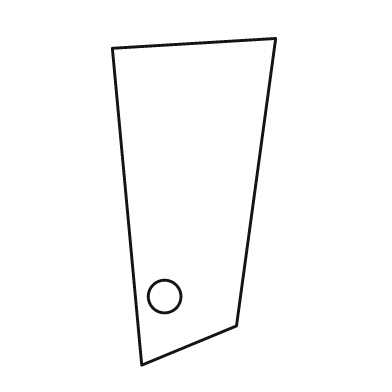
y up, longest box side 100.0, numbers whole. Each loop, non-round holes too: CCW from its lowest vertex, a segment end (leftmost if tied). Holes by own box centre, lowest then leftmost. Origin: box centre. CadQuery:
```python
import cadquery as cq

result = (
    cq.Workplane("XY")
    .moveTo(-16.0, -50.0)
    .lineTo(13.0, -38.0)
    .lineTo(25.0, 50.0)
    .lineTo(-25.0, 47.0)
    .close()
    .moveTo(-9.0, -29.0)
    .circle(5.0)
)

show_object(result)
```